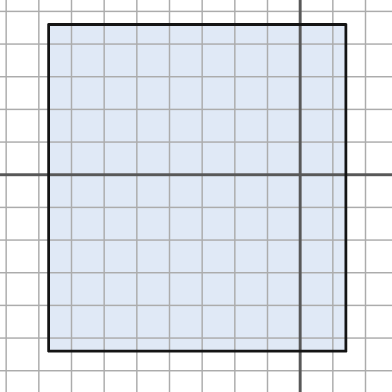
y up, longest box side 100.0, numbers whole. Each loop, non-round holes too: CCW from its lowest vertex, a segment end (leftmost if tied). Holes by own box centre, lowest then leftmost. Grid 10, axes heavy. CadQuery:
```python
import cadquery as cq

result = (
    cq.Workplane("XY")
    .moveTo(-77.0, -54.0)
    .lineTo(14.0, -54.0)
    .lineTo(14.0, 46.0)
    .lineTo(-77.0, 46.0)
    .close()
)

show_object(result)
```